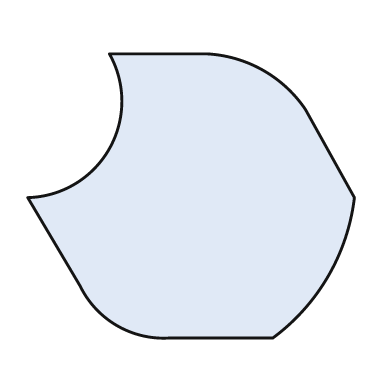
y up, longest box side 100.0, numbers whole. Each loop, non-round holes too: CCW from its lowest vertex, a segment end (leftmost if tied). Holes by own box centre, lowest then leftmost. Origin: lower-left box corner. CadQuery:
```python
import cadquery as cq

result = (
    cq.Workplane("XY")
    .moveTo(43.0, 0.0)
    .lineTo(75.0, 0.0)
    .threePointArc((92.0, 19.0), (100.0, 43.0))
    .lineTo(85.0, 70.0)
    .threePointArc((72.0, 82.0), (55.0, 87.0))
    .lineTo(25.0, 87.0)
    .threePointArc((25.0, 58.0), (0.0, 43.0))
    .lineTo(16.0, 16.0)
    .threePointArc((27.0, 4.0), (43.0, 0.0))
    .close()
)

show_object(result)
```